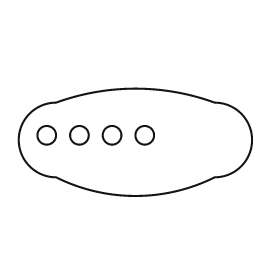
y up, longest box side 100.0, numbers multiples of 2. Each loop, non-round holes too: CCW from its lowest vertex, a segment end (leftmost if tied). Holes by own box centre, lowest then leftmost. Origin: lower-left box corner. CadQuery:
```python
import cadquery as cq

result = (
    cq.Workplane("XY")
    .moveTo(16.0, 8.0)
    .threePointArc((50.0, 0.0), (84.0, 8.0))
    .threePointArc((100.0, 24.0), (84.0, 40.0))
    .threePointArc((50.0, 46.0), (16.0, 40.0))
    .threePointArc((0.0, 24.0), (16.0, 8.0))
    .close()
    .moveTo(12.0, 26.0)
    .circle(4.0)
    .moveTo(26.0, 26.0)
    .circle(4.0)
    .moveTo(40.0, 26.0)
    .circle(4.0)
    .moveTo(54.0, 26.0)
    .circle(4.0)
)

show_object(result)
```